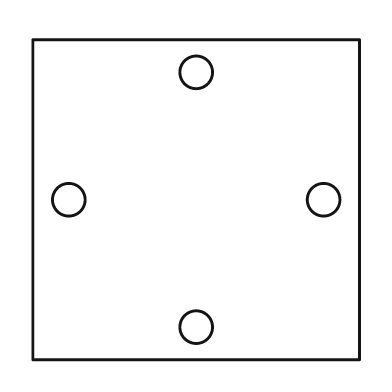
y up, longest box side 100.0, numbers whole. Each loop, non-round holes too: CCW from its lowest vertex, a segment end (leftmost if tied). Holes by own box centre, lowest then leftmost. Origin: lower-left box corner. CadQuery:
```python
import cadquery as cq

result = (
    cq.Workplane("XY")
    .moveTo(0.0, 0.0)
    .lineTo(100.0, 0.0)
    .lineTo(100.0, 98.0)
    .lineTo(0.0, 98.0)
    .close()
    .moveTo(50.0, 10.0)
    .circle(5.0)
    .moveTo(11.0, 49.0)
    .circle(5.0)
    .moveTo(89.0, 49.0)
    .circle(5.0)
    .moveTo(50.0, 88.0)
    .circle(5.0)
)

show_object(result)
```